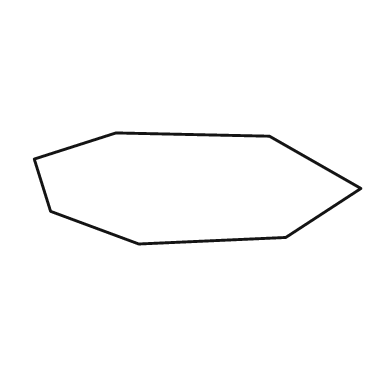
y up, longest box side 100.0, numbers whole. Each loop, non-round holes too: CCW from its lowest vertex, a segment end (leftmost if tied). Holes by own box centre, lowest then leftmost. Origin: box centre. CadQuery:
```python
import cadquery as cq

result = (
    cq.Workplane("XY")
    .moveTo(-18.0, -17.0)
    .lineTo(27.0, -15.0)
    .lineTo(50.0, 0.0)
    .lineTo(22.0, 16.0)
    .lineTo(-25.0, 17.0)
    .lineTo(-50.0, 9.0)
    .lineTo(-45.0, -7.0)
    .close()
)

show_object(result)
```